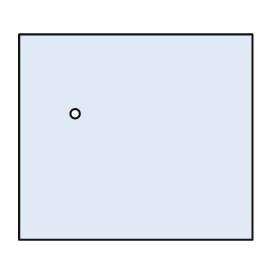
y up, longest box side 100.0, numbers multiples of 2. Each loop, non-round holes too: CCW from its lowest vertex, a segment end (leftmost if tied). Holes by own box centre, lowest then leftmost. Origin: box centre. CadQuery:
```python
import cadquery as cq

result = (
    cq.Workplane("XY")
    .moveTo(-50.0, -44.0)
    .lineTo(50.0, -44.0)
    .lineTo(50.0, 44.0)
    .lineTo(-50.0, 44.0)
    .close()
    .moveTo(-26.0, 10.0)
    .circle(2.0)
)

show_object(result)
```